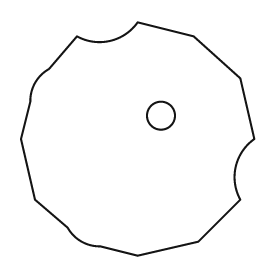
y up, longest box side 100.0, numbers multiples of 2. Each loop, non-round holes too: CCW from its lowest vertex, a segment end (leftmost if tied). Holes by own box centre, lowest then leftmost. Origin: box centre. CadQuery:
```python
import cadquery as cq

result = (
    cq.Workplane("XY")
    .moveTo(0.0, -50.0)
    .lineTo(26.0, -44.0)
    .lineTo(44.0, -26.0)
    .threePointArc((42.0, -12.0), (50.0, 0.0))
    .lineTo(44.0, 26.0)
    .lineTo(24.0, 44.0)
    .lineTo(0.0, 50.0)
    .threePointArc((-12.0, 42.0), (-26.0, 44.0))
    .lineTo(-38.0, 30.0)
    .threePointArc((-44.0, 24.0), (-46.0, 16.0))
    .lineTo(-50.0, 0.0)
    .lineTo(-44.0, -26.0)
    .lineTo(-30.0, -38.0)
    .threePointArc((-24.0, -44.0), (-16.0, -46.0))
    .close()
    .moveTo(10.0, 10.0)
    .circle(6.0)
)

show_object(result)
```